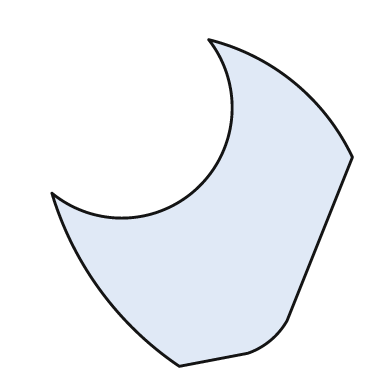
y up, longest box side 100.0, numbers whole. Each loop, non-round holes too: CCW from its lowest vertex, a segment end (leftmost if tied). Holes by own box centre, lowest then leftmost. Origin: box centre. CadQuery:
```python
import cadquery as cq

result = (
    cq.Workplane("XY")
    .moveTo(-7.0, -50.0)
    .lineTo(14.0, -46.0)
    .threePointArc((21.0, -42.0), (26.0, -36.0))
    .lineTo(46.0, 14.0)
    .threePointArc((28.0, 37.0), (2.0, 50.0))
    .threePointArc((-1.0, 5.0), (-46.0, 3.0))
    .threePointArc((-31.0, -27.0), (-7.0, -50.0))
    .close()
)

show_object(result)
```